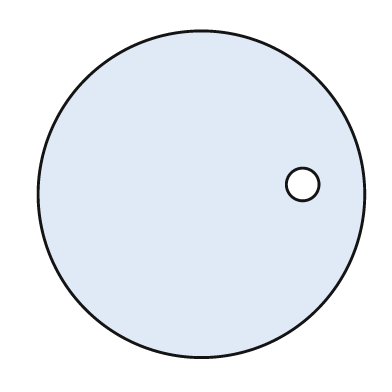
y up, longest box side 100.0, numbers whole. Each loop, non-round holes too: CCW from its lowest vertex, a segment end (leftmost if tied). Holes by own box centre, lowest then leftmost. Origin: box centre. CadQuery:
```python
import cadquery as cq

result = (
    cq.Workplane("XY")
    .moveTo(0.0, 0.0)
    .circle(50.0)
    .moveTo(31.0, 3.0)
    .circle(5.0)
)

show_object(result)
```